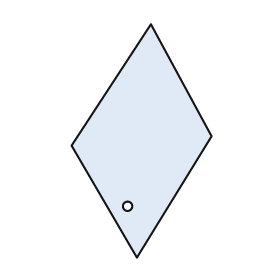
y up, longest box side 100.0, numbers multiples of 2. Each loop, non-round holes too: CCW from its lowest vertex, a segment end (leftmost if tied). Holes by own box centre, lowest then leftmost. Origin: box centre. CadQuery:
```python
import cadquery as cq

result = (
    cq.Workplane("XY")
    .moveTo(-2.0, -50.0)
    .lineTo(30.0, 2.0)
    .lineTo(4.0, 50.0)
    .lineTo(-30.0, -2.0)
    .close()
    .moveTo(-6.0, -28.0)
    .circle(2.0)
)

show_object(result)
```